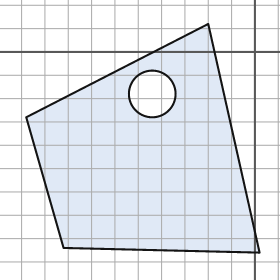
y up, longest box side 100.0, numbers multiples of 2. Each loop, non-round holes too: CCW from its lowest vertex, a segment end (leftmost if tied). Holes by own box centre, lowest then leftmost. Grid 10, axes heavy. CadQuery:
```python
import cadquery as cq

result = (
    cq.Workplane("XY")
    .moveTo(2.0, -86.0)
    .lineTo(-20.0, 12.0)
    .lineTo(-98.0, -28.0)
    .lineTo(-82.0, -84.0)
    .close()
    .moveTo(-44.0, -18.0)
    .circle(10.0)
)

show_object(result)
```